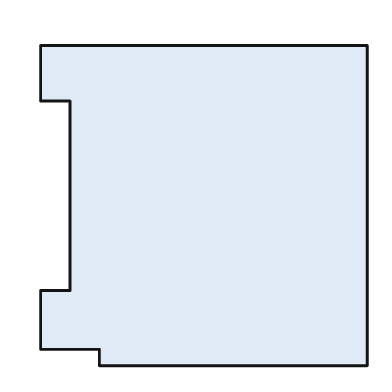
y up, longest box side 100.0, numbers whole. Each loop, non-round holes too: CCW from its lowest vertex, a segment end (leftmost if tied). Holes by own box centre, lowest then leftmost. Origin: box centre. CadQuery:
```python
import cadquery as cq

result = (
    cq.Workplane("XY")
    .moveTo(-32.0, -49.0)
    .lineTo(50.0, -49.0)
    .lineTo(50.0, 49.0)
    .lineTo(-50.0, 49.0)
    .lineTo(-50.0, 32.0)
    .lineTo(-41.0, 32.0)
    .lineTo(-41.0, -26.0)
    .lineTo(-50.0, -26.0)
    .lineTo(-50.0, -44.0)
    .lineTo(-32.0, -44.0)
    .close()
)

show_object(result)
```